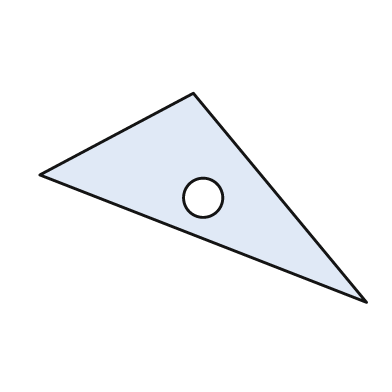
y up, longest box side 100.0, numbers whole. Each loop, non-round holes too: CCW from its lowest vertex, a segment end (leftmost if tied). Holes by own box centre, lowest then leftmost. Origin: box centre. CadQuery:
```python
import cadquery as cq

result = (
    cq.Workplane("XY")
    .moveTo(50.0, -32.0)
    .lineTo(-3.0, 32.0)
    .lineTo(-50.0, 7.0)
    .close()
    .moveTo(0.0, 0.0)
    .circle(6.0)
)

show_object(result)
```